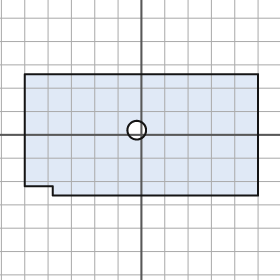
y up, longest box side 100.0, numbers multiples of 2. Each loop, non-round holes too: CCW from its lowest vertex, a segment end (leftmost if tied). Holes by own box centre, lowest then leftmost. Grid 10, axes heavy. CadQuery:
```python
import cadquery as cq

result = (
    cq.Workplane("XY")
    .moveTo(-38.0, -26.0)
    .lineTo(50.0, -26.0)
    .lineTo(50.0, 26.0)
    .lineTo(-50.0, 26.0)
    .lineTo(-50.0, -22.0)
    .lineTo(-38.0, -22.0)
    .close()
    .moveTo(-2.0, 2.0)
    .circle(4.0)
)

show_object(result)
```